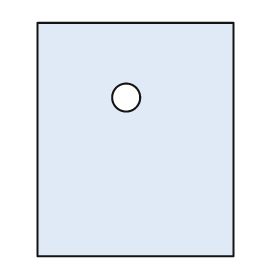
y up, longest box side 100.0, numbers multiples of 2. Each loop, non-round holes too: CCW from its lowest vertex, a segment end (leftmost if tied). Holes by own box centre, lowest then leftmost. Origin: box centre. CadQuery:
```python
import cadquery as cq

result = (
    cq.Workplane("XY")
    .moveTo(-42.0, -50.0)
    .lineTo(42.0, -50.0)
    .lineTo(42.0, 50.0)
    .lineTo(-42.0, 50.0)
    .close()
    .moveTo(-4.0, 18.0)
    .circle(6.0)
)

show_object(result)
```